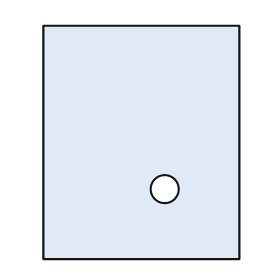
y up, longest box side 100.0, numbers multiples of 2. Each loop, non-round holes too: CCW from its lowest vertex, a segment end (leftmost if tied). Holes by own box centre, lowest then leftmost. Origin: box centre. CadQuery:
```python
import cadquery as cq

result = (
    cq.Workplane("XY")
    .moveTo(-42.0, -50.0)
    .lineTo(42.0, -50.0)
    .lineTo(42.0, 50.0)
    .lineTo(-42.0, 50.0)
    .close()
    .moveTo(10.0, -20.0)
    .circle(6.0)
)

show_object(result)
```